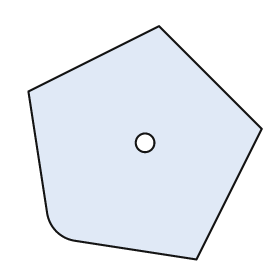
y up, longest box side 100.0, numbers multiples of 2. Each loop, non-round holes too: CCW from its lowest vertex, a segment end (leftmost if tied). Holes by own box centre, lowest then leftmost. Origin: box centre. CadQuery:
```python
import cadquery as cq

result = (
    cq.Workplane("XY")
    .moveTo(22.0, -50.0)
    .lineTo(50.0, 6.0)
    .lineTo(6.0, 50.0)
    .lineTo(-50.0, 22.0)
    .lineTo(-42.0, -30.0)
    .threePointArc((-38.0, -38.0), (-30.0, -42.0))
    .close()
    .moveTo(0.0, 0.0)
    .circle(4.0)
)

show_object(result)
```